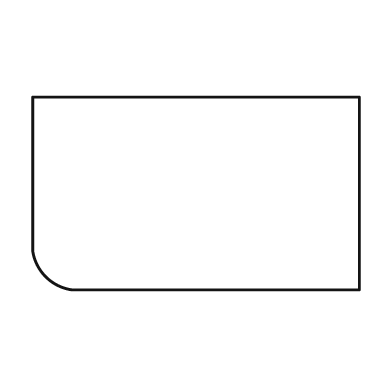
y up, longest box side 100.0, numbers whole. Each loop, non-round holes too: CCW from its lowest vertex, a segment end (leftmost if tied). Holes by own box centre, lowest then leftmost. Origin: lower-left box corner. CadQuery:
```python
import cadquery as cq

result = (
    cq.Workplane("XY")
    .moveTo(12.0, 0.0)
    .lineTo(100.0, 0.0)
    .lineTo(100.0, 59.0)
    .lineTo(0.0, 59.0)
    .lineTo(0.0, 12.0)
    .threePointArc((4.0, 4.0), (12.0, 0.0))
    .close()
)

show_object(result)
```